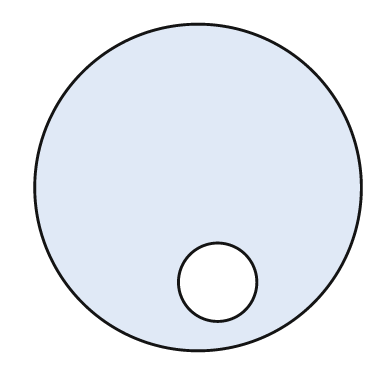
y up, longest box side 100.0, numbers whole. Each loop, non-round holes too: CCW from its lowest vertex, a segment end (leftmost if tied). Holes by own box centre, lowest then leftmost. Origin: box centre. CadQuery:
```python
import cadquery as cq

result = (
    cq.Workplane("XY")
    .moveTo(0.0, 0.0)
    .circle(50.0)
    .moveTo(6.0, -29.0)
    .circle(12.0)
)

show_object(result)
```